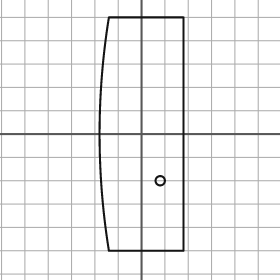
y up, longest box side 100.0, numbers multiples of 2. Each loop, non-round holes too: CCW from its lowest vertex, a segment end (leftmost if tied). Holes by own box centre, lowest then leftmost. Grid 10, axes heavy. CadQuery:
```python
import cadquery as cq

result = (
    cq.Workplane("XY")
    .moveTo(-14.0, -50.0)
    .lineTo(18.0, -50.0)
    .lineTo(18.0, 50.0)
    .lineTo(-14.0, 50.0)
    .threePointArc((-18.0, 0.0), (-14.0, -50.0))
    .close()
    .moveTo(8.0, -20.0)
    .circle(2.0)
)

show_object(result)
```